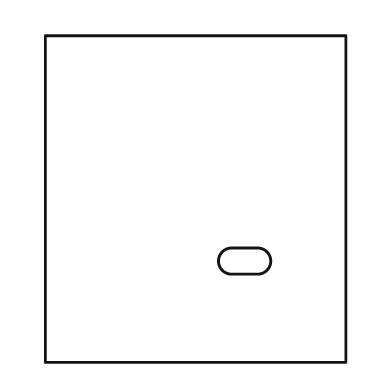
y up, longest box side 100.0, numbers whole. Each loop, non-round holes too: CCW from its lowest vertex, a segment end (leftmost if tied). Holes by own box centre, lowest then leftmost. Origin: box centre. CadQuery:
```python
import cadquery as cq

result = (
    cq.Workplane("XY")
    .moveTo(-46.0, -50.0)
    .lineTo(46.0, -50.0)
    .lineTo(46.0, 50.0)
    .lineTo(-46.0, 50.0)
    .close()
    .moveTo(11.0, -23.0)
    .lineTo(19.0, -23.0)
    .threePointArc((23.0, -19.0), (19.0, -15.0))
    .lineTo(11.0, -15.0)
    .threePointArc((7.0, -19.0), (11.0, -23.0))
    .close()
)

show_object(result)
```